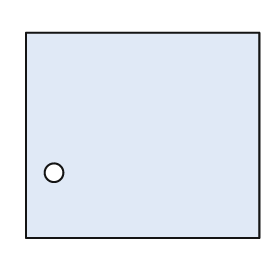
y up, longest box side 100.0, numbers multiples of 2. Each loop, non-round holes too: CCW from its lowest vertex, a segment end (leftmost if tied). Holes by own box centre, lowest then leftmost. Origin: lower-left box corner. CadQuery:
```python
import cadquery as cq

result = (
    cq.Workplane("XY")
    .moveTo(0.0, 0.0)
    .lineTo(100.0, 0.0)
    .lineTo(100.0, 88.0)
    .lineTo(0.0, 88.0)
    .close()
    .moveTo(12.0, 28.0)
    .circle(4.0)
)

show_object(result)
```